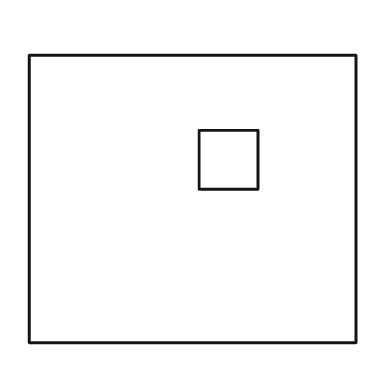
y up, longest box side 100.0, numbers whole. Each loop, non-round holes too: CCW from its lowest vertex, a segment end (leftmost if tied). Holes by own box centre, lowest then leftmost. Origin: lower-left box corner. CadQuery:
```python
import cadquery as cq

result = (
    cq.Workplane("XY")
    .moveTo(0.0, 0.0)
    .lineTo(100.0, 0.0)
    .lineTo(100.0, 88.0)
    .lineTo(0.0, 88.0)
    .close()
    .moveTo(52.0, 47.0)
    .lineTo(70.0, 47.0)
    .lineTo(70.0, 65.0)
    .lineTo(52.0, 65.0)
    .close()
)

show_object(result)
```